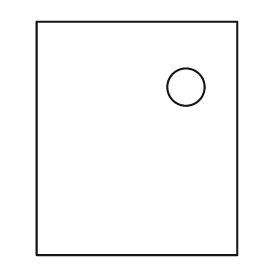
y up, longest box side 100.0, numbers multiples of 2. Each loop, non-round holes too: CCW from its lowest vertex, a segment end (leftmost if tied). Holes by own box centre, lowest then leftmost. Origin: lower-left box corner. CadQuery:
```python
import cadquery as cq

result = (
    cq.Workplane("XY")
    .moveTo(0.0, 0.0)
    .lineTo(86.0, 0.0)
    .lineTo(86.0, 100.0)
    .lineTo(0.0, 100.0)
    .close()
    .moveTo(64.0, 72.0)
    .circle(8.0)
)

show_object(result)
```